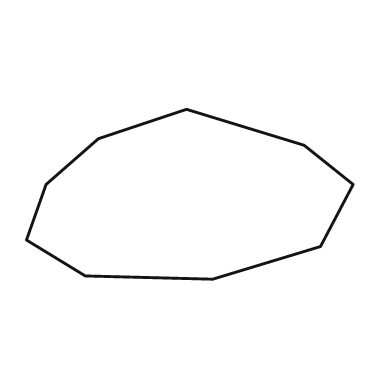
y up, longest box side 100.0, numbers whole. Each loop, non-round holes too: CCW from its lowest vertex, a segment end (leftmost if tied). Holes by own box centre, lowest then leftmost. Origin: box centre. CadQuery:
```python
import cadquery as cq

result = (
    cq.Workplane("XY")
    .moveTo(7.0, -26.0)
    .lineTo(40.0, -16.0)
    .lineTo(50.0, 3.0)
    .lineTo(35.0, 15.0)
    .lineTo(-1.0, 26.0)
    .lineTo(-28.0, 17.0)
    .lineTo(-44.0, 3.0)
    .lineTo(-50.0, -14.0)
    .lineTo(-32.0, -25.0)
    .close()
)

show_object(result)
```